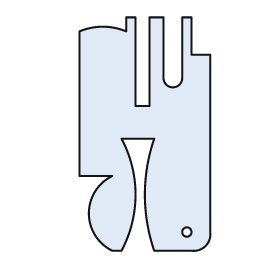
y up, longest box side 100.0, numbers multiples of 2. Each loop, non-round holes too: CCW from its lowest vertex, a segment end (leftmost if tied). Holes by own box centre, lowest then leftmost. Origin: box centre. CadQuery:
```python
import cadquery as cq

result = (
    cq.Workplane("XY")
    .moveTo(-14.0, -50.0)
    .lineTo(-10.0, -50.0)
    .threePointArc((-4.0, -26.0), (-10.0, -2.0))
    .lineTo(4.0, -2.0)
    .threePointArc((0.0, -26.0), (4.0, -50.0))
    .lineTo(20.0, -50.0)
    .threePointArc((26.0, -48.0), (28.0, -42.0))
    .lineTo(28.0, 34.0)
    .lineTo(20.0, 34.0)
    .lineTo(20.0, 50.0)
    .lineTo(16.0, 50.0)
    .lineTo(16.0, 24.0)
    .threePointArc((12.0, 20.0), (8.0, 24.0))
    .lineTo(8.0, 50.0)
    .lineTo(2.0, 50.0)
    .lineTo(2.0, 12.0)
    .lineTo(-4.0, 12.0)
    .lineTo(-4.0, 50.0)
    .lineTo(-8.0, 50.0)
    .lineTo(-8.0, 44.0)
    .threePointArc((-18.0, 46.0), (-28.0, 44.0))
    .lineTo(-28.0, -18.0)
    .lineTo(-14.0, -18.0)
    .threePointArc((-24.0, -34.0), (-14.0, -50.0))
    .close()
    .moveTo(18.0, -42.0)
    .circle(2.0)
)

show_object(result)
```